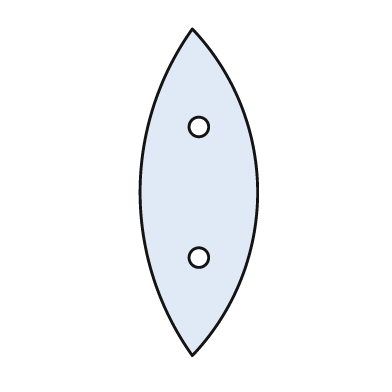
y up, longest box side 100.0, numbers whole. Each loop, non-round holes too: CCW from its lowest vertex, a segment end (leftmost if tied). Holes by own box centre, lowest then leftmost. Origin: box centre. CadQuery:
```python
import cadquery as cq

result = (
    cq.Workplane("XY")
    .moveTo(-2.0, -50.0)
    .threePointArc((18.0, 0.0), (-2.0, 50.0))
    .threePointArc((-18.0, 0.0), (-2.0, -50.0))
    .close()
    .moveTo(0.0, -20.0)
    .circle(3.0)
    .moveTo(0.0, 20.0)
    .circle(3.0)
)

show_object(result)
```